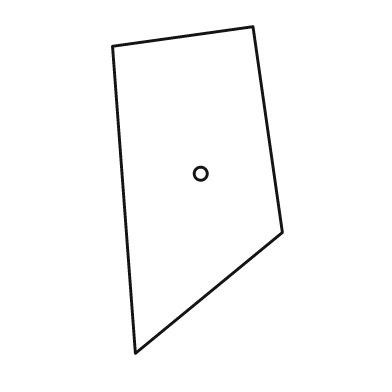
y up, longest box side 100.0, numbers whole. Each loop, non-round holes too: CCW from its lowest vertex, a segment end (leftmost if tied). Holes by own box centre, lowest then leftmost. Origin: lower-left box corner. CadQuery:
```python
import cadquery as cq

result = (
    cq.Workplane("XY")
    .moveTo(7.0, 0.0)
    .lineTo(52.0, 37.0)
    .lineTo(43.0, 100.0)
    .lineTo(0.0, 94.0)
    .close()
    .moveTo(27.0, 55.0)
    .circle(2.0)
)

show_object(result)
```